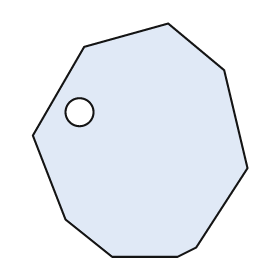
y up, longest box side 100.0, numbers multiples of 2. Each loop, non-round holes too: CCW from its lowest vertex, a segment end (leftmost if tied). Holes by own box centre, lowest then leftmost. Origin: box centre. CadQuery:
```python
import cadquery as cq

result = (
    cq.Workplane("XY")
    .moveTo(-12.0, -50.0)
    .lineTo(16.0, -50.0)
    .lineTo(24.0, -46.0)
    .lineTo(46.0, -12.0)
    .lineTo(36.0, 30.0)
    .lineTo(12.0, 50.0)
    .lineTo(-24.0, 40.0)
    .lineTo(-46.0, 2.0)
    .lineTo(-32.0, -34.0)
    .close()
    .moveTo(-26.0, 12.0)
    .circle(6.0)
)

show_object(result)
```